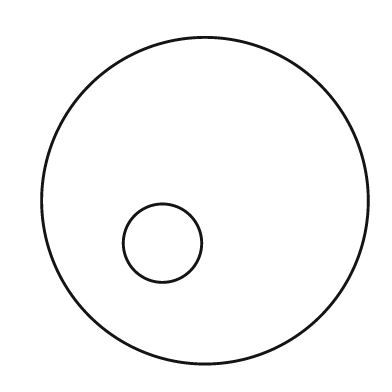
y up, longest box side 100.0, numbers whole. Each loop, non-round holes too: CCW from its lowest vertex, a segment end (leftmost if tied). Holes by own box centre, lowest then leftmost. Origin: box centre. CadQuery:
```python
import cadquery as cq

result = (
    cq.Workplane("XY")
    .moveTo(0.0, 0.0)
    .circle(50.0)
    .moveTo(-13.0, -13.0)
    .circle(12.0)
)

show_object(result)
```